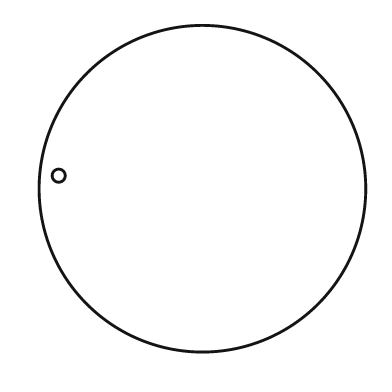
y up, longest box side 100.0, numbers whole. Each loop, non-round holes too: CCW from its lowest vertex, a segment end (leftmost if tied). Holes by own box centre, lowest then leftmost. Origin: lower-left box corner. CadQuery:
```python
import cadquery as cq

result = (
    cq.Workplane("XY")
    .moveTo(50.0, 50.0)
    .circle(50.0)
    .moveTo(6.0, 54.0)
    .circle(2.0)
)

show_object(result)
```